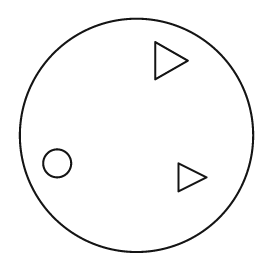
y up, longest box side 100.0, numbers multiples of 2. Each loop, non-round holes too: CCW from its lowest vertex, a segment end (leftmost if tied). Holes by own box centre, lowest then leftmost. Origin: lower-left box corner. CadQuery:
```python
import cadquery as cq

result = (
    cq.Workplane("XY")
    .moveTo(50.0, 50.0)
    .circle(50.0)
    .moveTo(68.0, 26.0)
    .lineTo(80.0, 32.0)
    .lineTo(68.0, 38.0)
    .close()
    .moveTo(16.0, 38.0)
    .circle(6.0)
    .moveTo(58.0, 74.0)
    .lineTo(72.0, 82.0)
    .lineTo(58.0, 90.0)
    .close()
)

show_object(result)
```